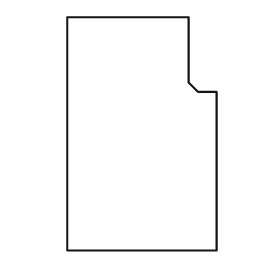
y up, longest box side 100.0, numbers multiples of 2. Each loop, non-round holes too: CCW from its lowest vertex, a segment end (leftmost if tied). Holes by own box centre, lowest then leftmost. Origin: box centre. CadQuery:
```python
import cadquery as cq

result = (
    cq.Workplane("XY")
    .moveTo(-32.0, -50.0)
    .lineTo(32.0, -50.0)
    .lineTo(32.0, 18.0)
    .lineTo(24.0, 18.0)
    .lineTo(20.0, 22.0)
    .lineTo(20.0, 50.0)
    .lineTo(-32.0, 50.0)
    .close()
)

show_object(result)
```